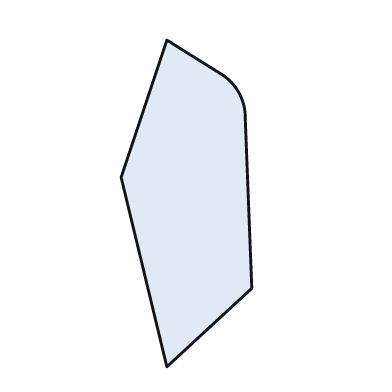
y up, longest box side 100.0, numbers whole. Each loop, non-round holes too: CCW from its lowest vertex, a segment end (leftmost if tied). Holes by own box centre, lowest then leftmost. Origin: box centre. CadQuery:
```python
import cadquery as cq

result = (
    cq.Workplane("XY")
    .moveTo(-6.0, -50.0)
    .lineTo(20.0, -26.0)
    .lineTo(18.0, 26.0)
    .threePointArc((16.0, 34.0), (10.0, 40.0))
    .lineTo(-6.0, 50.0)
    .lineTo(-20.0, 8.0)
    .close()
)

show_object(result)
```